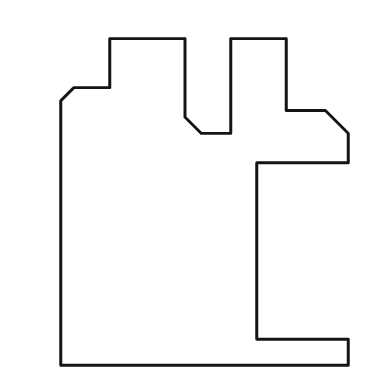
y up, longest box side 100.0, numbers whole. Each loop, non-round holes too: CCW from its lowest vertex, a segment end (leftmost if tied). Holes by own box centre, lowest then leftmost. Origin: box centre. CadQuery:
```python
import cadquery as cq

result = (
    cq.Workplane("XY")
    .moveTo(-44.0, -50.0)
    .lineTo(44.0, -50.0)
    .lineTo(44.0, -42.0)
    .lineTo(16.0, -42.0)
    .lineTo(16.0, 12.0)
    .lineTo(44.0, 12.0)
    .lineTo(44.0, 21.0)
    .lineTo(37.0, 28.0)
    .lineTo(25.0, 28.0)
    .lineTo(25.0, 50.0)
    .lineTo(8.0, 50.0)
    .lineTo(8.0, 21.0)
    .lineTo(-1.0, 21.0)
    .lineTo(-6.0, 26.0)
    .lineTo(-6.0, 50.0)
    .lineTo(-29.0, 50.0)
    .lineTo(-29.0, 35.0)
    .lineTo(-40.0, 35.0)
    .lineTo(-44.0, 31.0)
    .close()
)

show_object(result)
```